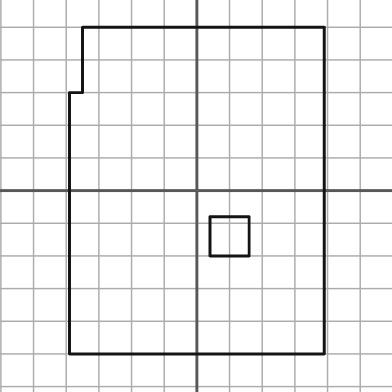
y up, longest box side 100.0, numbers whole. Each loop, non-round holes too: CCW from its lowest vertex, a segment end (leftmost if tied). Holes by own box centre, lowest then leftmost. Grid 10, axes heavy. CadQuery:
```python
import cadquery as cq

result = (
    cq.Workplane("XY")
    .moveTo(-39.0, -50.0)
    .lineTo(39.0, -50.0)
    .lineTo(39.0, 50.0)
    .lineTo(-35.0, 50.0)
    .lineTo(-35.0, 30.0)
    .lineTo(-39.0, 30.0)
    .close()
    .moveTo(4.0, -20.0)
    .lineTo(16.0, -20.0)
    .lineTo(16.0, -8.0)
    .lineTo(4.0, -8.0)
    .close()
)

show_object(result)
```